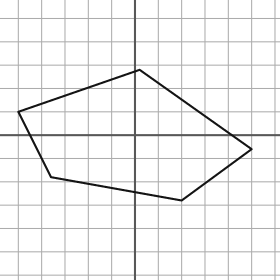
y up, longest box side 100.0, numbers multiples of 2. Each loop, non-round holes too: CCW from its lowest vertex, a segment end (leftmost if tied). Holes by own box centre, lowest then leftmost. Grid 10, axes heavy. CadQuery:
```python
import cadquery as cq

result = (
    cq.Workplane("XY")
    .moveTo(20.0, -28.0)
    .lineTo(50.0, -6.0)
    .lineTo(2.0, 28.0)
    .lineTo(-50.0, 10.0)
    .lineTo(-36.0, -18.0)
    .close()
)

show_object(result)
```